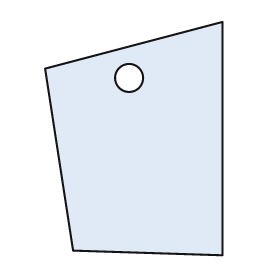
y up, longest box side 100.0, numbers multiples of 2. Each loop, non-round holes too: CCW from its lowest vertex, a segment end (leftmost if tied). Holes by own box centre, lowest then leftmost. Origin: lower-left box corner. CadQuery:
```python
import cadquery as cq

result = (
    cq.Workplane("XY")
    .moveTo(76.0, 0.0)
    .lineTo(76.0, 100.0)
    .lineTo(0.0, 80.0)
    .lineTo(12.0, 2.0)
    .close()
    .moveTo(36.0, 76.0)
    .circle(6.0)
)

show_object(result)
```